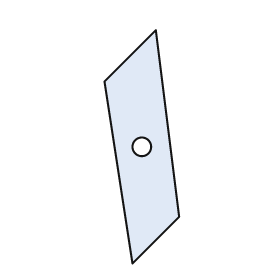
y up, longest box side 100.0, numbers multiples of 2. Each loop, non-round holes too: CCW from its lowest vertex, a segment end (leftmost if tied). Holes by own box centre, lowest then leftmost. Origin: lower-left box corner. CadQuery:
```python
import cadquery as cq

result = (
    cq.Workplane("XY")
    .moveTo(12.0, 0.0)
    .lineTo(32.0, 20.0)
    .lineTo(22.0, 100.0)
    .lineTo(0.0, 78.0)
    .close()
    .moveTo(16.0, 50.0)
    .circle(4.0)
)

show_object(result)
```